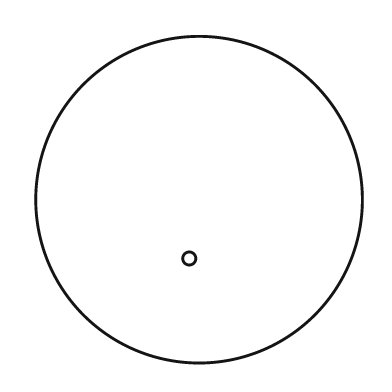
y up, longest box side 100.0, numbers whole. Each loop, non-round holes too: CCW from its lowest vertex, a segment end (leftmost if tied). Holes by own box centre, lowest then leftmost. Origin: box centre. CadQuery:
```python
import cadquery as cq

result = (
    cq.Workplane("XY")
    .moveTo(0.0, 0.0)
    .circle(50.0)
    .moveTo(-3.0, -18.0)
    .circle(2.0)
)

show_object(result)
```